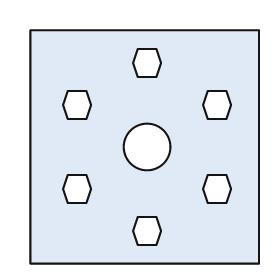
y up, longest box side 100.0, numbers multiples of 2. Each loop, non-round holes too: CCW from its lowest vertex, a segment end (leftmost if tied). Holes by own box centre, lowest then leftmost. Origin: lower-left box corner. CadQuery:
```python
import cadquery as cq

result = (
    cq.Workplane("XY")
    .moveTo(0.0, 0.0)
    .lineTo(98.0, 0.0)
    .lineTo(98.0, 100.0)
    .lineTo(0.0, 100.0)
    .close()
    .moveTo(46.0, 8.0)
    .lineTo(54.0, 8.0)
    .lineTo(56.0, 14.0)
    .lineTo(54.0, 20.0)
    .lineTo(46.0, 20.0)
    .lineTo(44.0, 14.0)
    .close()
    .moveTo(16.0, 26.0)
    .lineTo(24.0, 26.0)
    .lineTo(26.0, 32.0)
    .lineTo(24.0, 38.0)
    .lineTo(16.0, 38.0)
    .lineTo(14.0, 32.0)
    .close()
    .moveTo(76.0, 26.0)
    .lineTo(84.0, 26.0)
    .lineTo(86.0, 32.0)
    .lineTo(84.0, 38.0)
    .lineTo(76.0, 38.0)
    .lineTo(74.0, 32.0)
    .close()
    .moveTo(50.0, 50.0)
    .circle(10.0)
    .moveTo(16.0, 62.0)
    .lineTo(24.0, 62.0)
    .lineTo(26.0, 68.0)
    .lineTo(24.0, 74.0)
    .lineTo(16.0, 74.0)
    .lineTo(14.0, 68.0)
    .close()
    .moveTo(76.0, 62.0)
    .lineTo(84.0, 62.0)
    .lineTo(86.0, 68.0)
    .lineTo(84.0, 74.0)
    .lineTo(76.0, 74.0)
    .lineTo(74.0, 68.0)
    .close()
    .moveTo(46.0, 80.0)
    .lineTo(54.0, 80.0)
    .lineTo(56.0, 86.0)
    .lineTo(54.0, 92.0)
    .lineTo(46.0, 92.0)
    .lineTo(44.0, 86.0)
    .close()
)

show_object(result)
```